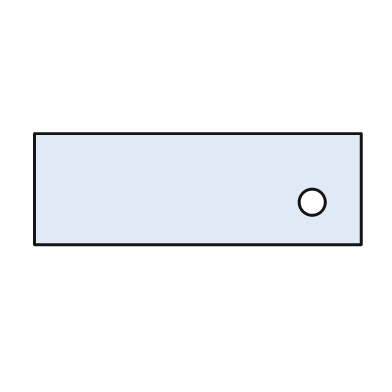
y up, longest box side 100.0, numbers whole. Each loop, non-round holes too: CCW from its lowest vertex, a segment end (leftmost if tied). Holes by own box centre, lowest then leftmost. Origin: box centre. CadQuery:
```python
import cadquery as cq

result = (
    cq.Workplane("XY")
    .moveTo(-50.0, -17.0)
    .lineTo(50.0, -17.0)
    .lineTo(50.0, 17.0)
    .lineTo(-50.0, 17.0)
    .close()
    .moveTo(35.0, -4.0)
    .circle(4.0)
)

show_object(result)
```